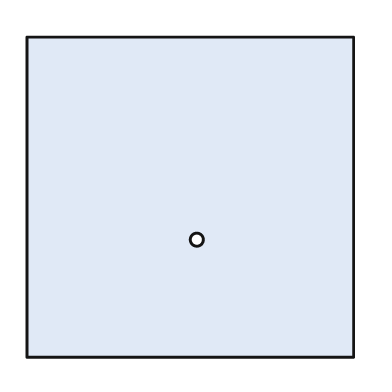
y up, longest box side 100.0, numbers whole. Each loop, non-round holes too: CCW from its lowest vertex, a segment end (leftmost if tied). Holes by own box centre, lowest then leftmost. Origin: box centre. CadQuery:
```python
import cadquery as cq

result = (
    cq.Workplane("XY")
    .moveTo(-50.0, -49.0)
    .lineTo(50.0, -49.0)
    .lineTo(50.0, 49.0)
    .lineTo(-50.0, 49.0)
    .close()
    .moveTo(2.0, -13.0)
    .circle(2.0)
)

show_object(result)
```